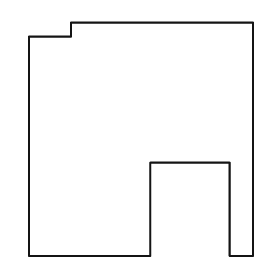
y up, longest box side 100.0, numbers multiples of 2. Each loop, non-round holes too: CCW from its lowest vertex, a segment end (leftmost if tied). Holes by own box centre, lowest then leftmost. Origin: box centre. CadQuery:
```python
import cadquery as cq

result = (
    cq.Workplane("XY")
    .moveTo(-48.0, -50.0)
    .lineTo(4.0, -50.0)
    .lineTo(4.0, -10.0)
    .lineTo(38.0, -10.0)
    .lineTo(38.0, -50.0)
    .lineTo(48.0, -50.0)
    .lineTo(48.0, 50.0)
    .lineTo(-30.0, 50.0)
    .lineTo(-30.0, 44.0)
    .lineTo(-48.0, 44.0)
    .close()
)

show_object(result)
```